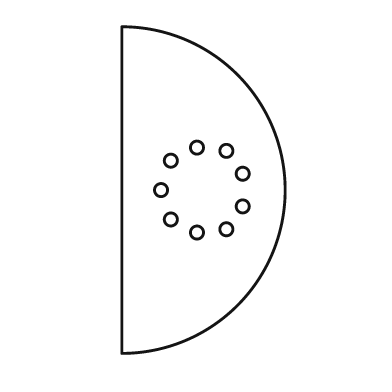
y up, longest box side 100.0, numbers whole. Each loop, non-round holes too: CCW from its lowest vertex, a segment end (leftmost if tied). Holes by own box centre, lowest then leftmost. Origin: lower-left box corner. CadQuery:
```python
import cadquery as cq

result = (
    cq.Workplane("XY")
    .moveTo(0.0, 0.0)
    .threePointArc((50.0, 50.0), (0.0, 100.0))
    .close()
    .moveTo(23.0, 37.0)
    .circle(2.0)
    .moveTo(32.0, 38.0)
    .circle(2.0)
    .moveTo(15.0, 41.0)
    .circle(2.0)
    .moveTo(37.0, 45.0)
    .circle(2.0)
    .moveTo(12.0, 50.0)
    .circle(2.0)
    .moveTo(37.0, 55.0)
    .circle(2.0)
    .moveTo(15.0, 59.0)
    .circle(2.0)
    .moveTo(32.0, 62.0)
    .circle(2.0)
    .moveTo(23.0, 63.0)
    .circle(2.0)
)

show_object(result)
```